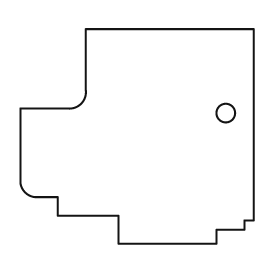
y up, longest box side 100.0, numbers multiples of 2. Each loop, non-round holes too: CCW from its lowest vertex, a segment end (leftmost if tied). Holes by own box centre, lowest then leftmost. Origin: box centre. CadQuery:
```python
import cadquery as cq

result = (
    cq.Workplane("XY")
    .moveTo(-8.0, -46.0)
    .lineTo(34.0, -46.0)
    .lineTo(34.0, -40.0)
    .lineTo(46.0, -40.0)
    .lineTo(46.0, -36.0)
    .lineTo(50.0, -36.0)
    .lineTo(50.0, 46.0)
    .lineTo(-22.0, 46.0)
    .lineTo(-22.0, 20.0)
    .threePointArc((-24.0, 14.0), (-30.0, 12.0))
    .lineTo(-50.0, 12.0)
    .lineTo(-50.0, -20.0)
    .threePointArc((-48.0, -24.0), (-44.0, -26.0))
    .lineTo(-34.0, -26.0)
    .lineTo(-34.0, -34.0)
    .lineTo(-8.0, -34.0)
    .close()
    .moveTo(38.0, 10.0)
    .circle(4.0)
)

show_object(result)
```